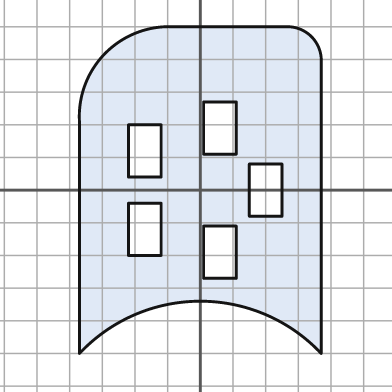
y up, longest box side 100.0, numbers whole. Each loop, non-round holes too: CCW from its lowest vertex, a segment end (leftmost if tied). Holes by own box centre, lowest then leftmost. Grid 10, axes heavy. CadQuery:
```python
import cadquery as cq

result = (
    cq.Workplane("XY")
    .moveTo(-37.0, -50.0)
    .threePointArc((0.0, -34.0), (37.0, -50.0))
    .lineTo(37.0, 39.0)
    .threePointArc((34.0, 47.0), (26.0, 50.0))
    .lineTo(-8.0, 50.0)
    .threePointArc((-29.0, 42.0), (-37.0, 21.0))
    .close()
    .moveTo(1.0, -27.0)
    .lineTo(11.0, -27.0)
    .lineTo(11.0, -11.0)
    .lineTo(1.0, -11.0)
    .close()
    .moveTo(-22.0, -20.0)
    .lineTo(-12.0, -20.0)
    .lineTo(-12.0, -4.0)
    .lineTo(-22.0, -4.0)
    .close()
    .moveTo(15.0, -8.0)
    .lineTo(25.0, -8.0)
    .lineTo(25.0, 8.0)
    .lineTo(15.0, 8.0)
    .close()
    .moveTo(-22.0, 4.0)
    .lineTo(-12.0, 4.0)
    .lineTo(-12.0, 20.0)
    .lineTo(-22.0, 20.0)
    .close()
    .moveTo(1.0, 11.0)
    .lineTo(11.0, 11.0)
    .lineTo(11.0, 27.0)
    .lineTo(1.0, 27.0)
    .close()
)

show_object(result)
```